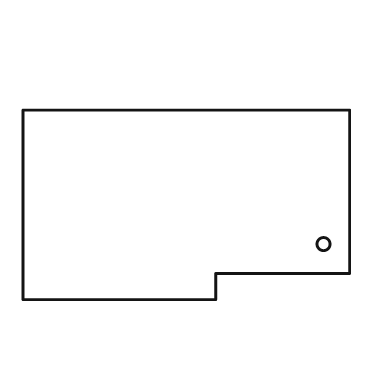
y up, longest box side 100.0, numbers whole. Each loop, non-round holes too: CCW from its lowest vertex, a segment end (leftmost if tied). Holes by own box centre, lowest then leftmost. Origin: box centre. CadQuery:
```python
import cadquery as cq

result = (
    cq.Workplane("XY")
    .moveTo(-50.0, -29.0)
    .lineTo(9.0, -29.0)
    .lineTo(9.0, -21.0)
    .lineTo(50.0, -21.0)
    .lineTo(50.0, 29.0)
    .lineTo(-50.0, 29.0)
    .close()
    .moveTo(42.0, -12.0)
    .circle(2.0)
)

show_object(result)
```